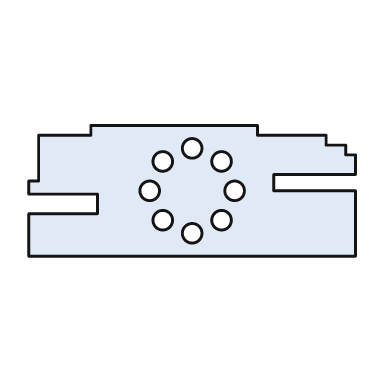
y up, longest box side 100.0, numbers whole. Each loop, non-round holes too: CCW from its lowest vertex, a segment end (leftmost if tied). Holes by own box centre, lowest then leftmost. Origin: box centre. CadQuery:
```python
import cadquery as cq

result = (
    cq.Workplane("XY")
    .moveTo(-50.0, -20.0)
    .lineTo(50.0, -20.0)
    .lineTo(50.0, 0.0)
    .lineTo(25.0, 0.0)
    .lineTo(25.0, 5.0)
    .lineTo(50.0, 5.0)
    .lineTo(50.0, 11.0)
    .lineTo(47.0, 11.0)
    .lineTo(47.0, 14.0)
    .lineTo(41.0, 14.0)
    .lineTo(41.0, 17.0)
    .lineTo(20.0, 17.0)
    .lineTo(20.0, 20.0)
    .lineTo(-31.0, 20.0)
    .lineTo(-31.0, 17.0)
    .lineTo(-47.0, 17.0)
    .lineTo(-47.0, 3.0)
    .lineTo(-50.0, 3.0)
    .lineTo(-50.0, -1.0)
    .lineTo(-29.0, -1.0)
    .lineTo(-29.0, -7.0)
    .lineTo(-50.0, -7.0)
    .close()
    .moveTo(0.0, -13.0)
    .circle(3.0)
    .moveTo(-9.0, -9.0)
    .circle(3.0)
    .moveTo(9.0, -9.0)
    .circle(3.0)
    .moveTo(-13.0, 0.0)
    .circle(3.0)
    .moveTo(13.0, 0.0)
    .circle(3.0)
    .moveTo(-9.0, 9.0)
    .circle(3.0)
    .moveTo(9.0, 9.0)
    .circle(3.0)
    .moveTo(0.0, 13.0)
    .circle(3.0)
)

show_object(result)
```